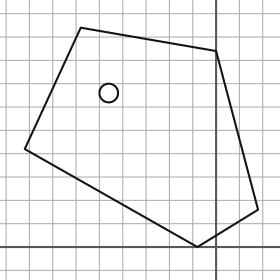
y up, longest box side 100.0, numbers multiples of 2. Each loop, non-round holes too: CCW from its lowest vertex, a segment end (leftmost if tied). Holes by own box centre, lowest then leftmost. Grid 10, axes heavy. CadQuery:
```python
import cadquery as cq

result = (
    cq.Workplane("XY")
    .moveTo(-8.0, 0.0)
    .lineTo(18.0, 16.0)
    .lineTo(0.0, 84.0)
    .lineTo(-58.0, 94.0)
    .lineTo(-82.0, 42.0)
    .close()
    .moveTo(-46.0, 66.0)
    .circle(4.0)
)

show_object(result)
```